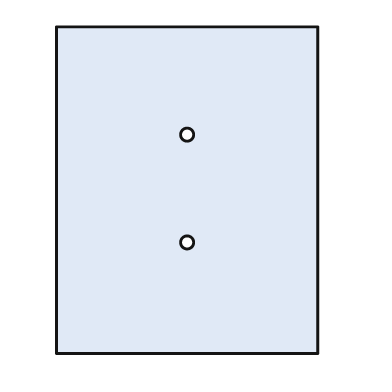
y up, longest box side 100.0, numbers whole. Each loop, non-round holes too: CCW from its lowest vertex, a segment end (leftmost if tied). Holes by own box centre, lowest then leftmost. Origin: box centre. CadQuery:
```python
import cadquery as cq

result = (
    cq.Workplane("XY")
    .moveTo(-40.0, -50.0)
    .lineTo(40.0, -50.0)
    .lineTo(40.0, 50.0)
    .lineTo(-40.0, 50.0)
    .close()
    .moveTo(0.0, -16.0)
    .circle(2.0)
    .moveTo(0.0, 17.0)
    .circle(2.0)
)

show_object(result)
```